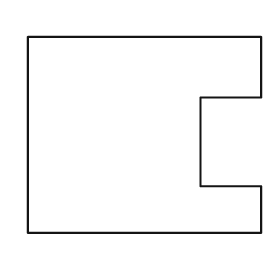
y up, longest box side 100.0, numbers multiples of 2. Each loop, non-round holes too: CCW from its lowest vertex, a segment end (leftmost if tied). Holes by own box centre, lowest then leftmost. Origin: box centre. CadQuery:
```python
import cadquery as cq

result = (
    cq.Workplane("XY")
    .moveTo(-50.0, -42.0)
    .lineTo(50.0, -42.0)
    .lineTo(50.0, -22.0)
    .lineTo(24.0, -22.0)
    .lineTo(24.0, 16.0)
    .lineTo(50.0, 16.0)
    .lineTo(50.0, 42.0)
    .lineTo(-50.0, 42.0)
    .close()
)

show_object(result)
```